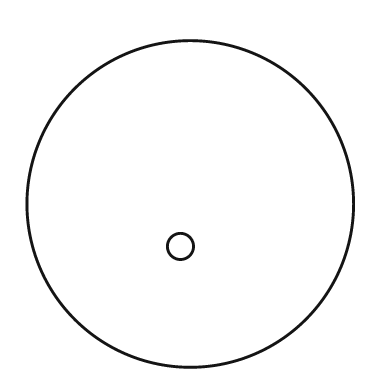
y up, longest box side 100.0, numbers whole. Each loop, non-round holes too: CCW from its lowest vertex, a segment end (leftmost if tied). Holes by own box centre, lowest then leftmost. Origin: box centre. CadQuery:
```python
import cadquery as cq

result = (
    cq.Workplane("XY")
    .moveTo(0.0, 0.0)
    .circle(50.0)
    .moveTo(-3.0, -13.0)
    .circle(4.0)
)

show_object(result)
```